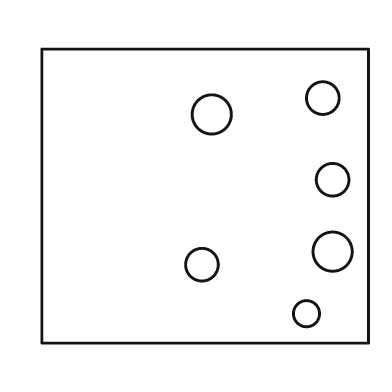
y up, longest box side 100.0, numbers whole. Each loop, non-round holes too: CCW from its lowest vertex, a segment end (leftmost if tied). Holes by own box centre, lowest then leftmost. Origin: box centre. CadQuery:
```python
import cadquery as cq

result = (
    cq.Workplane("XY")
    .moveTo(-50.0, -45.0)
    .lineTo(50.0, -45.0)
    .lineTo(50.0, 45.0)
    .lineTo(-50.0, 45.0)
    .close()
    .moveTo(31.0, -36.0)
    .circle(4.0)
    .moveTo(-1.0, -21.0)
    .circle(5.0)
    .moveTo(39.0, -17.0)
    .circle(6.0)
    .moveTo(39.0, 5.0)
    .circle(5.0)
    .moveTo(2.0, 25.0)
    .circle(6.0)
    .moveTo(36.0, 30.0)
    .circle(5.0)
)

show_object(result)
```